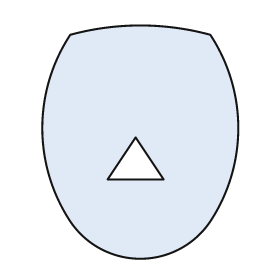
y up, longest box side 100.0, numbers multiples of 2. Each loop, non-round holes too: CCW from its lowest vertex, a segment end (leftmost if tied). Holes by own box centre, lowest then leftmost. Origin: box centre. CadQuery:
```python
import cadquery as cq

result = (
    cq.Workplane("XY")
    .moveTo(-30.0, -34.0)
    .threePointArc((0.0, -50.0), (30.0, -34.0))
    .threePointArc((42.0, 6.0), (30.0, 46.0))
    .threePointArc((0.0, 50.0), (-30.0, 46.0))
    .threePointArc((-42.0, 6.0), (-30.0, -34.0))
    .close()
    .moveTo(-14.0, -16.0)
    .lineTo(10.0, -16.0)
    .lineTo(-2.0, 2.0)
    .close()
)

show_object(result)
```